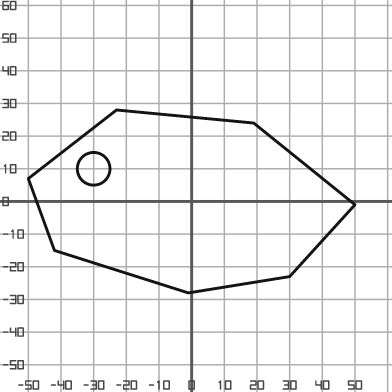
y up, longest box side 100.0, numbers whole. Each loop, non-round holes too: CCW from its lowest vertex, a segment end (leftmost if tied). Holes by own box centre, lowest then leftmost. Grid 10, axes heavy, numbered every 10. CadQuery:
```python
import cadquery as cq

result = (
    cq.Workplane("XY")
    .moveTo(-1.0, -28.0)
    .lineTo(30.0, -23.0)
    .lineTo(50.0, -1.0)
    .lineTo(19.0, 24.0)
    .lineTo(-23.0, 28.0)
    .lineTo(-50.0, 7.0)
    .lineTo(-42.0, -15.0)
    .close()
    .moveTo(-30.0, 10.0)
    .circle(5.0)
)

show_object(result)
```